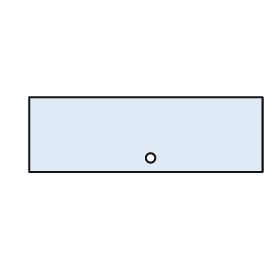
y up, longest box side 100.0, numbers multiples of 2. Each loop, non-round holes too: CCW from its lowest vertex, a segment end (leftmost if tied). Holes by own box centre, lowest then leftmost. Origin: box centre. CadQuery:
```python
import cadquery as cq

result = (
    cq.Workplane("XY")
    .moveTo(-50.0, -16.0)
    .lineTo(50.0, -16.0)
    .lineTo(50.0, 16.0)
    .lineTo(-50.0, 16.0)
    .close()
    .moveTo(2.0, -10.0)
    .circle(2.0)
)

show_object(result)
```